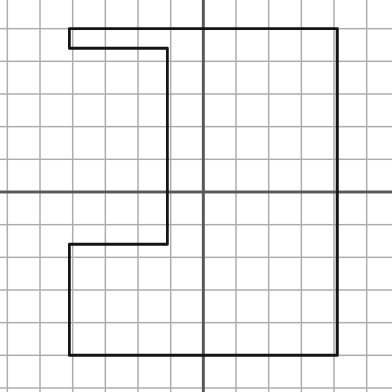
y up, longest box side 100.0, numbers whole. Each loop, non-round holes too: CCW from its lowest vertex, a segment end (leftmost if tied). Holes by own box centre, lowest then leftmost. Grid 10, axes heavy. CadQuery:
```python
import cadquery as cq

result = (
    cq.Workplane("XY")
    .moveTo(-41.0, -50.0)
    .lineTo(41.0, -50.0)
    .lineTo(41.0, 50.0)
    .lineTo(-41.0, 50.0)
    .lineTo(-41.0, 44.0)
    .lineTo(-11.0, 44.0)
    .lineTo(-11.0, -16.0)
    .lineTo(-41.0, -16.0)
    .close()
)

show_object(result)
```